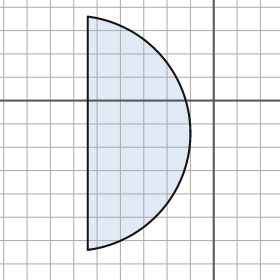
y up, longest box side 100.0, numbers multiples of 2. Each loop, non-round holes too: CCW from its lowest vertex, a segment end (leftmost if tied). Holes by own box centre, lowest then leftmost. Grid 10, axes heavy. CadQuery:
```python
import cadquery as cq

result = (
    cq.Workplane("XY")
    .moveTo(-54.0, -64.0)
    .threePointArc((-10.0, -14.0), (-54.0, 36.0))
    .close()
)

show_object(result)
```